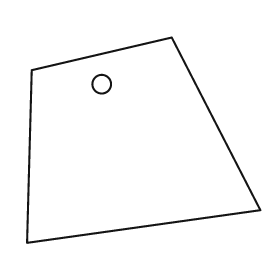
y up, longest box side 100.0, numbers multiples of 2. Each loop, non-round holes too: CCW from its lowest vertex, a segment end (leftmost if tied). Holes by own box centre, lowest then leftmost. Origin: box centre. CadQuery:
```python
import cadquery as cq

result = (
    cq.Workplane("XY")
    .moveTo(-50.0, -44.0)
    .lineTo(50.0, -30.0)
    .lineTo(12.0, 44.0)
    .lineTo(-48.0, 30.0)
    .close()
    .moveTo(-18.0, 24.0)
    .circle(4.0)
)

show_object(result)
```